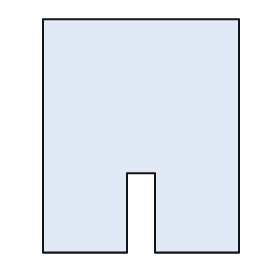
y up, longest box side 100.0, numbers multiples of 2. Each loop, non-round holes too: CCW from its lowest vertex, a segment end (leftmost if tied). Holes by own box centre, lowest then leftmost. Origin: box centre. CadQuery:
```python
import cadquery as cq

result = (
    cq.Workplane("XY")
    .moveTo(-42.0, -50.0)
    .lineTo(-6.0, -50.0)
    .lineTo(-6.0, -16.0)
    .lineTo(6.0, -16.0)
    .lineTo(6.0, -50.0)
    .lineTo(42.0, -50.0)
    .lineTo(42.0, 50.0)
    .lineTo(-42.0, 50.0)
    .close()
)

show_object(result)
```